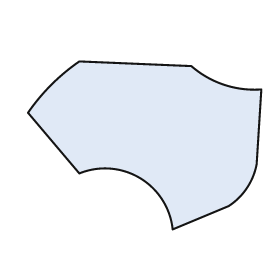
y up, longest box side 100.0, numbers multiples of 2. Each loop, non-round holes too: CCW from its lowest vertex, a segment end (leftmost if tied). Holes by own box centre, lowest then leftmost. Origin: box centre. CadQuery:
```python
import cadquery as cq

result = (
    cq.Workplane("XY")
    .moveTo(12.0, -36.0)
    .lineTo(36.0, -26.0)
    .threePointArc((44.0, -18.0), (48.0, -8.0))
    .lineTo(50.0, 24.0)
    .threePointArc((34.0, 26.0), (20.0, 34.0))
    .lineTo(-28.0, 36.0)
    .threePointArc((-40.0, 26.0), (-50.0, 14.0))
    .lineTo(-28.0, -12.0)
    .threePointArc((-2.0, -14.0), (12.0, -36.0))
    .close()
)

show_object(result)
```